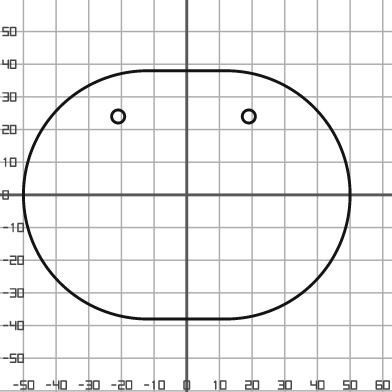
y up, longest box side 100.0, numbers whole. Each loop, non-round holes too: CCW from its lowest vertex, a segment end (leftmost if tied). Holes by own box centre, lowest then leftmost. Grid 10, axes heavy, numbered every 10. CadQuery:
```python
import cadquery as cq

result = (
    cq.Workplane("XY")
    .moveTo(-12.0, -38.0)
    .lineTo(12.0, -38.0)
    .threePointArc((50.0, 0.0), (12.0, 38.0))
    .lineTo(-12.0, 38.0)
    .threePointArc((-50.0, 0.0), (-12.0, -38.0))
    .close()
    .moveTo(-21.0, 24.0)
    .circle(2.0)
    .moveTo(19.0, 24.0)
    .circle(2.0)
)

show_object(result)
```